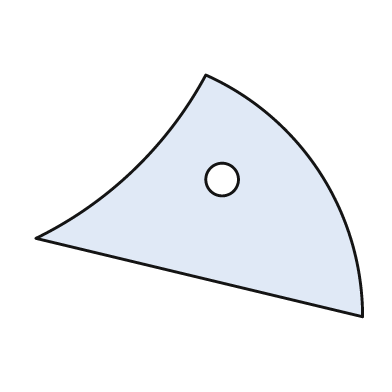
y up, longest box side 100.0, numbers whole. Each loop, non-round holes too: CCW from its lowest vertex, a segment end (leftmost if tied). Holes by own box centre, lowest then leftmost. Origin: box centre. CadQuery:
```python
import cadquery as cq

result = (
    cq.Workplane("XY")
    .moveTo(50.0, -37.0)
    .threePointArc((37.0, 7.0), (2.0, 37.0))
    .threePointArc((-20.0, 8.0), (-50.0, -13.0))
    .close()
    .moveTo(7.0, 5.0)
    .circle(5.0)
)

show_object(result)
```